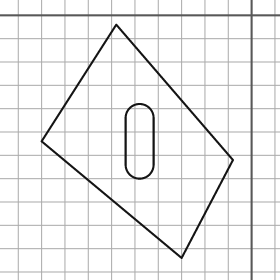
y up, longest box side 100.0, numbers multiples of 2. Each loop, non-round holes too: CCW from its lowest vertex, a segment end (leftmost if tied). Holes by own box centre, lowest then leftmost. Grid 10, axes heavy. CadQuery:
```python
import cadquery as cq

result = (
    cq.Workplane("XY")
    .moveTo(-30.0, -104.0)
    .lineTo(-8.0, -62.0)
    .lineTo(-58.0, -4.0)
    .lineTo(-90.0, -54.0)
    .close()
    .moveTo(-54.0, -64.0)
    .threePointArc((-48.0, -70.0), (-42.0, -64.0))
    .lineTo(-42.0, -44.0)
    .threePointArc((-48.0, -38.0), (-54.0, -44.0))
    .close()
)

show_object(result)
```